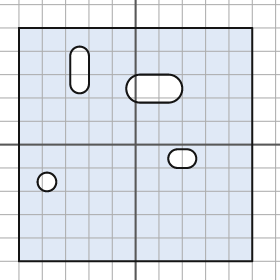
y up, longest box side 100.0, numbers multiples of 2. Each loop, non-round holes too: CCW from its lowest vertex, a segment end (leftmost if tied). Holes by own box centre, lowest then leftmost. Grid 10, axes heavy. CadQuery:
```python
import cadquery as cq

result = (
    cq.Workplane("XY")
    .moveTo(-50.0, -50.0)
    .lineTo(50.0, -50.0)
    .lineTo(50.0, 50.0)
    .lineTo(-50.0, 50.0)
    .close()
    .moveTo(-38.0, -16.0)
    .circle(4.0)
    .moveTo(18.0, -10.0)
    .lineTo(22.0, -10.0)
    .threePointArc((26.0, -6.0), (22.0, -2.0))
    .lineTo(18.0, -2.0)
    .threePointArc((14.0, -6.0), (18.0, -10.0))
    .close()
    .moveTo(2.0, 18.0)
    .lineTo(14.0, 18.0)
    .threePointArc((20.0, 24.0), (14.0, 30.0))
    .lineTo(2.0, 30.0)
    .threePointArc((-4.0, 24.0), (2.0, 18.0))
    .close()
    .moveTo(-28.0, 26.0)
    .threePointArc((-24.0, 22.0), (-20.0, 26.0))
    .lineTo(-20.0, 38.0)
    .threePointArc((-24.0, 42.0), (-28.0, 38.0))
    .close()
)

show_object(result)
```